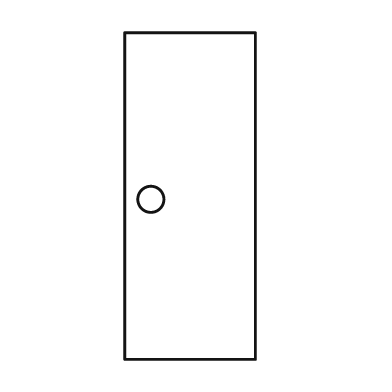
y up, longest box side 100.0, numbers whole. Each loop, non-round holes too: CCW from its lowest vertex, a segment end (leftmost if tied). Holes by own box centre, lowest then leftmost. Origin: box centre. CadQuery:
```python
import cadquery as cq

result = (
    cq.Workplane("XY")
    .moveTo(-20.0, -50.0)
    .lineTo(20.0, -50.0)
    .lineTo(20.0, 50.0)
    .lineTo(-20.0, 50.0)
    .close()
    .moveTo(-12.0, -1.0)
    .circle(4.0)
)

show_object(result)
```